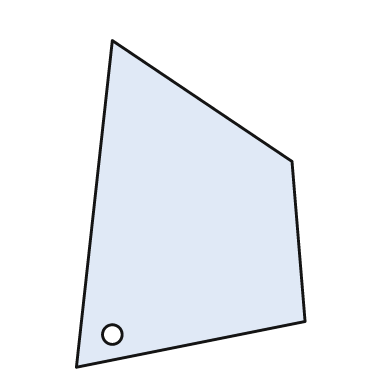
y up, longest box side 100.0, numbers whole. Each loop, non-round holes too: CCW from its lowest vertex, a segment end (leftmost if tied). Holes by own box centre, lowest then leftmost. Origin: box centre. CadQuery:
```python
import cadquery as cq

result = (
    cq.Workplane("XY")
    .moveTo(-35.0, -50.0)
    .lineTo(35.0, -36.0)
    .lineTo(31.0, 13.0)
    .lineTo(-24.0, 50.0)
    .close()
    .moveTo(-24.0, -40.0)
    .circle(3.0)
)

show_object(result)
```